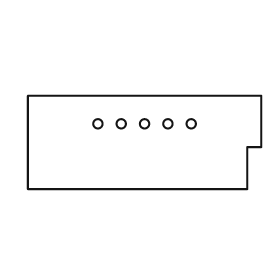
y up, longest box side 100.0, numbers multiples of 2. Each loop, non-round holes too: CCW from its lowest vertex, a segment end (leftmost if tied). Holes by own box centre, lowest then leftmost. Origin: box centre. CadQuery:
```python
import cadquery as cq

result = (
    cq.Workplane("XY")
    .moveTo(-50.0, -20.0)
    .lineTo(44.0, -20.0)
    .lineTo(44.0, -2.0)
    .lineTo(50.0, -2.0)
    .lineTo(50.0, 20.0)
    .lineTo(-50.0, 20.0)
    .close()
    .moveTo(-20.0, 8.0)
    .circle(2.0)
    .moveTo(-10.0, 8.0)
    .circle(2.0)
    .moveTo(0.0, 8.0)
    .circle(2.0)
    .moveTo(10.0, 8.0)
    .circle(2.0)
    .moveTo(20.0, 8.0)
    .circle(2.0)
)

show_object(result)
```